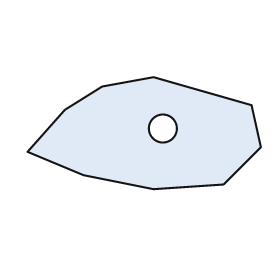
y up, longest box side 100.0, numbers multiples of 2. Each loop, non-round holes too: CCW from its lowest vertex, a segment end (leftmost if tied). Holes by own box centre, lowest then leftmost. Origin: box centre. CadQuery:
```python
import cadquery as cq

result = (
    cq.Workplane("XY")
    .moveTo(4.0, -24.0)
    .lineTo(34.0, -22.0)
    .lineTo(50.0, -6.0)
    .lineTo(46.0, 12.0)
    .lineTo(4.0, 24.0)
    .lineTo(-18.0, 20.0)
    .lineTo(-34.0, 10.0)
    .lineTo(-50.0, -8.0)
    .lineTo(-26.0, -18.0)
    .close()
    .moveTo(8.0, 2.0)
    .circle(6.0)
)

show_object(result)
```